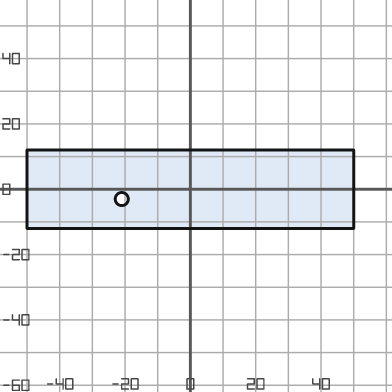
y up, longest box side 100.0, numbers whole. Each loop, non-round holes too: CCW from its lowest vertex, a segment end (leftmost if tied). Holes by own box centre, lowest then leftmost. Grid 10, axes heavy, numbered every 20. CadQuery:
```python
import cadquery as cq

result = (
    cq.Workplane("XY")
    .moveTo(-50.0, -12.0)
    .lineTo(50.0, -12.0)
    .lineTo(50.0, 12.0)
    .lineTo(-50.0, 12.0)
    .close()
    .moveTo(-21.0, -3.0)
    .circle(2.0)
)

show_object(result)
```